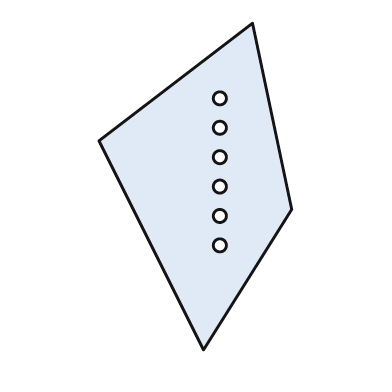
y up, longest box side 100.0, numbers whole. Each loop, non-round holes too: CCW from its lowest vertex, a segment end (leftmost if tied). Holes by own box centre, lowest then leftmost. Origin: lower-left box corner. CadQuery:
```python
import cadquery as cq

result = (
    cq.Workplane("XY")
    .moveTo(32.0, 0.0)
    .lineTo(59.0, 43.0)
    .lineTo(47.0, 100.0)
    .lineTo(0.0, 64.0)
    .close()
    .moveTo(37.0, 32.0)
    .circle(2.0)
    .moveTo(37.0, 41.0)
    .circle(2.0)
    .moveTo(37.0, 50.0)
    .circle(2.0)
    .moveTo(37.0, 59.0)
    .circle(2.0)
    .moveTo(37.0, 68.0)
    .circle(2.0)
    .moveTo(37.0, 77.0)
    .circle(2.0)
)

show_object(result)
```